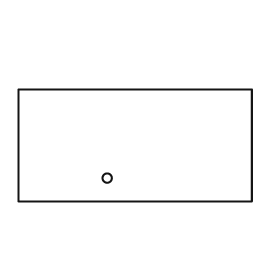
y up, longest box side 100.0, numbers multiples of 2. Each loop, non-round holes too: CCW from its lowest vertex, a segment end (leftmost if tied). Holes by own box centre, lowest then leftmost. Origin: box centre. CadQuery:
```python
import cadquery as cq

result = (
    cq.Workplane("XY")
    .moveTo(-50.0, -24.0)
    .lineTo(50.0, -24.0)
    .lineTo(50.0, 24.0)
    .lineTo(-50.0, 24.0)
    .close()
    .moveTo(-12.0, -14.0)
    .circle(2.0)
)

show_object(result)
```